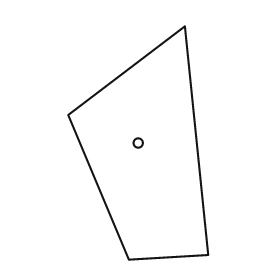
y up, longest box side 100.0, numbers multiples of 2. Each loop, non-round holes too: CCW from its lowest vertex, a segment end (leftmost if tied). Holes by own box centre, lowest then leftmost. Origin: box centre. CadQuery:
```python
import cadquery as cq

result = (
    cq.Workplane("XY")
    .moveTo(-4.0, -50.0)
    .lineTo(30.0, -48.0)
    .lineTo(20.0, 50.0)
    .lineTo(-30.0, 12.0)
    .close()
    .moveTo(0.0, 0.0)
    .circle(2.0)
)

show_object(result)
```